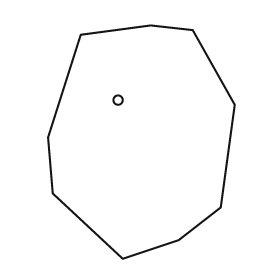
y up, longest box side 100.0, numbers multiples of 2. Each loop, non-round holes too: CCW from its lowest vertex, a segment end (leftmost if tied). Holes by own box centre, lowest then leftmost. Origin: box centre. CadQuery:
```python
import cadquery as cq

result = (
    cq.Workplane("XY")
    .moveTo(-8.0, -50.0)
    .lineTo(16.0, -42.0)
    .lineTo(34.0, -28.0)
    .lineTo(40.0, 16.0)
    .lineTo(22.0, 48.0)
    .lineTo(4.0, 50.0)
    .lineTo(-26.0, 46.0)
    .lineTo(-40.0, 2.0)
    .lineTo(-38.0, -22.0)
    .close()
    .moveTo(-10.0, 18.0)
    .circle(2.0)
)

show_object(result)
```